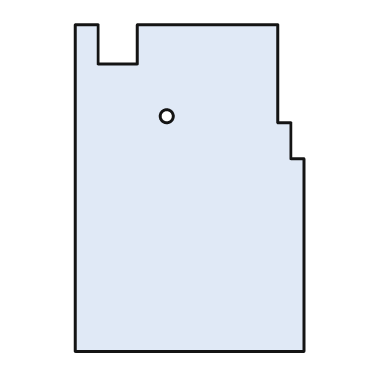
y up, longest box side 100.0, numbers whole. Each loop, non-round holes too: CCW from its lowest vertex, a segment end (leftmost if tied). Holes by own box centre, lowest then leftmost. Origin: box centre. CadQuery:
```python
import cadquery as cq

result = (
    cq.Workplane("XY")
    .moveTo(-35.0, -50.0)
    .lineTo(35.0, -50.0)
    .lineTo(35.0, 9.0)
    .lineTo(31.0, 9.0)
    .lineTo(31.0, 20.0)
    .lineTo(27.0, 20.0)
    .lineTo(27.0, 50.0)
    .lineTo(-16.0, 50.0)
    .lineTo(-16.0, 38.0)
    .lineTo(-28.0, 38.0)
    .lineTo(-28.0, 50.0)
    .lineTo(-35.0, 50.0)
    .close()
    .moveTo(-7.0, 22.0)
    .circle(2.0)
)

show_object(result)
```